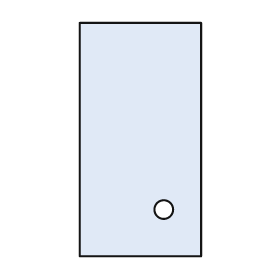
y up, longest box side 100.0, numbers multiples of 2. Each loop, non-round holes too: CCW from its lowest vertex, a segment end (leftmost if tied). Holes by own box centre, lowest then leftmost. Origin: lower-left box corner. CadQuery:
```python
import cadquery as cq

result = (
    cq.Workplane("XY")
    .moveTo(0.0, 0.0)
    .lineTo(52.0, 0.0)
    .lineTo(52.0, 100.0)
    .lineTo(0.0, 100.0)
    .close()
    .moveTo(36.0, 20.0)
    .circle(4.0)
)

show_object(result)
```